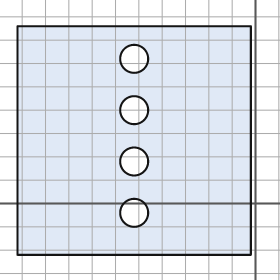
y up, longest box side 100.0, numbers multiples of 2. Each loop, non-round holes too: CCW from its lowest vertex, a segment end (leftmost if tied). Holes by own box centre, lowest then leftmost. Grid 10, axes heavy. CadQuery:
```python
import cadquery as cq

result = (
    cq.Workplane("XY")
    .moveTo(-102.0, -22.0)
    .lineTo(-2.0, -22.0)
    .lineTo(-2.0, 76.0)
    .lineTo(-102.0, 76.0)
    .close()
    .moveTo(-52.0, -4.0)
    .circle(6.0)
    .moveTo(-52.0, 18.0)
    .circle(6.0)
    .moveTo(-52.0, 40.0)
    .circle(6.0)
    .moveTo(-52.0, 62.0)
    .circle(6.0)
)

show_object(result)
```